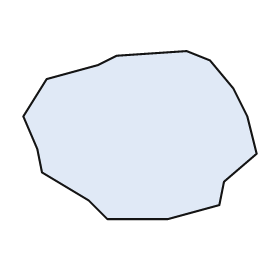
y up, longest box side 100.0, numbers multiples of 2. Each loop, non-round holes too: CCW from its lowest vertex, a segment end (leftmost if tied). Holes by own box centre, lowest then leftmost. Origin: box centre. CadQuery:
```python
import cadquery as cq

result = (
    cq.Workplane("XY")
    .moveTo(-14.0, -36.0)
    .lineTo(12.0, -36.0)
    .lineTo(34.0, -30.0)
    .lineTo(36.0, -20.0)
    .lineTo(50.0, -8.0)
    .lineTo(46.0, 8.0)
    .lineTo(40.0, 20.0)
    .lineTo(30.0, 32.0)
    .lineTo(20.0, 36.0)
    .lineTo(-10.0, 34.0)
    .lineTo(-18.0, 30.0)
    .lineTo(-40.0, 24.0)
    .lineTo(-50.0, 8.0)
    .lineTo(-44.0, -6.0)
    .lineTo(-42.0, -16.0)
    .lineTo(-22.0, -28.0)
    .close()
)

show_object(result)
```